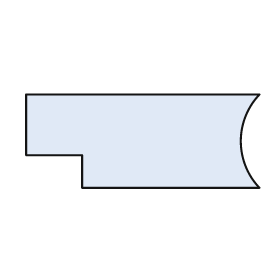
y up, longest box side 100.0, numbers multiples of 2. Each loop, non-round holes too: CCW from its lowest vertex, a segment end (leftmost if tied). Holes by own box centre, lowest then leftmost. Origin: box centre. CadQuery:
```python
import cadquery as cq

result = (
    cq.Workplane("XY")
    .moveTo(-26.0, -20.0)
    .lineTo(50.0, -20.0)
    .threePointArc((42.0, 0.0), (50.0, 20.0))
    .lineTo(-50.0, 20.0)
    .lineTo(-50.0, -6.0)
    .lineTo(-26.0, -6.0)
    .close()
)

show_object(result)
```